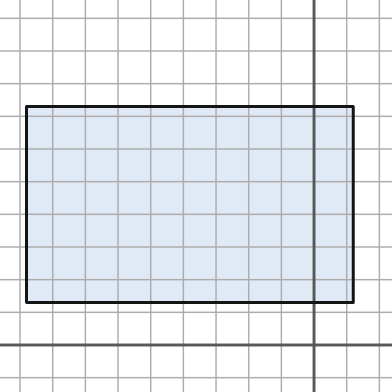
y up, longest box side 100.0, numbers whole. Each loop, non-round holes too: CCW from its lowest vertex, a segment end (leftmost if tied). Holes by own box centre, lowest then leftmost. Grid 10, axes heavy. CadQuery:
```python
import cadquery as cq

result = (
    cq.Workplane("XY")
    .moveTo(-88.0, 13.0)
    .lineTo(12.0, 13.0)
    .lineTo(12.0, 73.0)
    .lineTo(-88.0, 73.0)
    .close()
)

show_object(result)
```